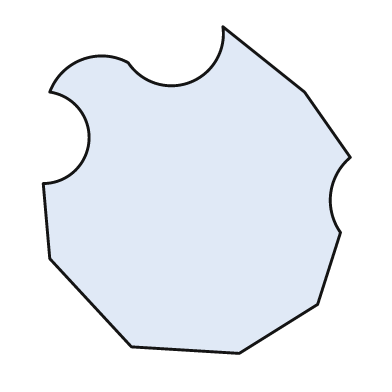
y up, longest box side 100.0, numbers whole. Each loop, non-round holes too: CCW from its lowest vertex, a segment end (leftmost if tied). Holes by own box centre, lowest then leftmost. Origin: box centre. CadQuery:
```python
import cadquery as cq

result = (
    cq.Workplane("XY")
    .moveTo(13.0, -50.0)
    .lineTo(37.0, -35.0)
    .lineTo(44.0, -13.0)
    .threePointArc((41.0, -1.0), (47.0, 10.0))
    .lineTo(33.0, 30.0)
    .lineTo(8.0, 50.0)
    .threePointArc((-2.0, 33.0), (-21.0, 39.0))
    .threePointArc((-35.0, 40.0), (-45.0, 30.0))
    .threePointArc((-33.0, 15.0), (-47.0, 2.0))
    .lineTo(-45.0, -21.0)
    .lineTo(-20.0, -48.0)
    .close()
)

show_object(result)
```